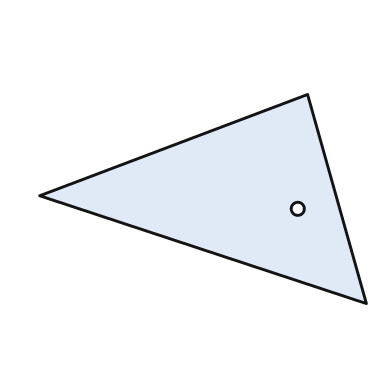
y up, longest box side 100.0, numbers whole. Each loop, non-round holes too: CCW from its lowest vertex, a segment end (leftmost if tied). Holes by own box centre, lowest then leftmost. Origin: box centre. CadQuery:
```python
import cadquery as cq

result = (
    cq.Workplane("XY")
    .moveTo(50.0, -32.0)
    .lineTo(32.0, 32.0)
    .lineTo(-50.0, 1.0)
    .close()
    .moveTo(29.0, -3.0)
    .circle(2.0)
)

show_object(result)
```